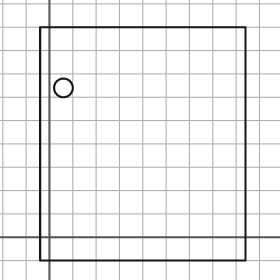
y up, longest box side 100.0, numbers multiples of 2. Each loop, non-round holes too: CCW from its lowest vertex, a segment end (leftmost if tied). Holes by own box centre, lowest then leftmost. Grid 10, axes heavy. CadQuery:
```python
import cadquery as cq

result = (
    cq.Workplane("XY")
    .moveTo(-4.0, -10.0)
    .lineTo(84.0, -10.0)
    .lineTo(84.0, 90.0)
    .lineTo(-4.0, 90.0)
    .close()
    .moveTo(6.0, 64.0)
    .circle(4.0)
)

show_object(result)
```